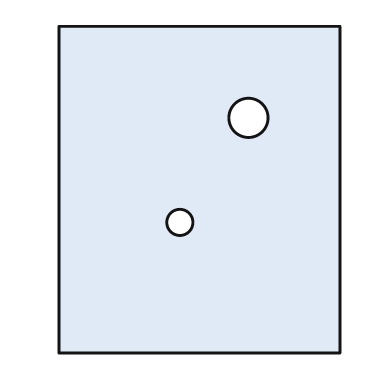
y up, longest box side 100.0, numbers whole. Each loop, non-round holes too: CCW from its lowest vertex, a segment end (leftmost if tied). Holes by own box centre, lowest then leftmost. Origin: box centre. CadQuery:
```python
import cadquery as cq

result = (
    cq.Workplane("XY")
    .moveTo(-43.0, -50.0)
    .lineTo(43.0, -50.0)
    .lineTo(43.0, 50.0)
    .lineTo(-43.0, 50.0)
    .close()
    .moveTo(-6.0, -10.0)
    .circle(4.0)
    .moveTo(15.0, 22.0)
    .circle(6.0)
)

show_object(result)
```